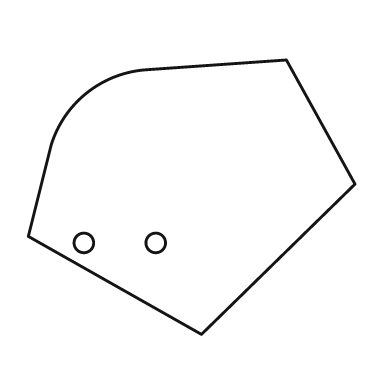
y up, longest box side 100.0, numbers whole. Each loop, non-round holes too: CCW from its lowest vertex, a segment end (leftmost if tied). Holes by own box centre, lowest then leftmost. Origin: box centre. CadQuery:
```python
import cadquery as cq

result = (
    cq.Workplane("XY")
    .moveTo(3.0, -42.0)
    .lineTo(50.0, 4.0)
    .lineTo(29.0, 42.0)
    .lineTo(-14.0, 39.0)
    .threePointArc((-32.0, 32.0), (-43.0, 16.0))
    .lineTo(-50.0, -12.0)
    .close()
    .moveTo(-33.0, -14.0)
    .circle(3.0)
    .moveTo(-11.0, -14.0)
    .circle(3.0)
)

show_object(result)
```